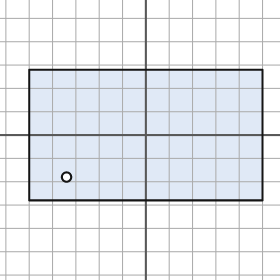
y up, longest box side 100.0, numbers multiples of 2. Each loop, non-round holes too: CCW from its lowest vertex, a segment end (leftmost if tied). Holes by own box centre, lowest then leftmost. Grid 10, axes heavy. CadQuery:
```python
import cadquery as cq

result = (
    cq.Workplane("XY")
    .moveTo(-50.0, -28.0)
    .lineTo(50.0, -28.0)
    .lineTo(50.0, 28.0)
    .lineTo(-50.0, 28.0)
    .close()
    .moveTo(-34.0, -18.0)
    .circle(2.0)
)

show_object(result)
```